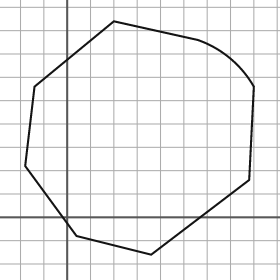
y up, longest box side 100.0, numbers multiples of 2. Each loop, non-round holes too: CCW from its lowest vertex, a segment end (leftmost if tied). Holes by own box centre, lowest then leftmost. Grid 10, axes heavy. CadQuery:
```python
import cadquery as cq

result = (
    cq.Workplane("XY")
    .moveTo(36.0, -16.0)
    .lineTo(78.0, 16.0)
    .lineTo(80.0, 56.0)
    .threePointArc((70.0, 68.0), (56.0, 76.0))
    .lineTo(20.0, 84.0)
    .lineTo(-14.0, 56.0)
    .lineTo(-18.0, 22.0)
    .lineTo(4.0, -8.0)
    .close()
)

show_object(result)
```